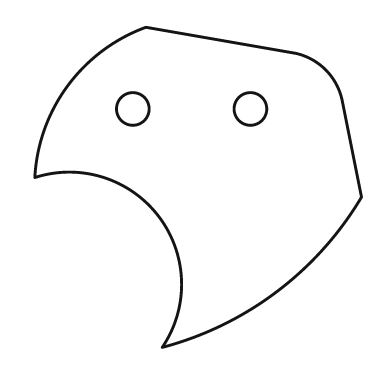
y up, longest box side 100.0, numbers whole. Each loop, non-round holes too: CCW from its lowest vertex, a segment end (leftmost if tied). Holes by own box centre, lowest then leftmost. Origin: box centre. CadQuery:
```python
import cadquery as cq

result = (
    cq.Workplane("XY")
    .moveTo(-11.0, -49.0)
    .threePointArc((24.0, -32.0), (50.0, -3.0))
    .lineTo(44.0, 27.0)
    .threePointArc((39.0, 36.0), (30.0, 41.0))
    .lineTo(-16.0, 49.0)
    .threePointArc((-40.0, 31.0), (-50.0, 3.0))
    .threePointArc((-12.0, -9.0), (-11.0, -49.0))
    .close()
    .moveTo(-20.0, 24.0)
    .circle(5.0)
    .moveTo(16.0, 24.0)
    .circle(5.0)
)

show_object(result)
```